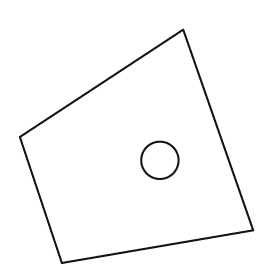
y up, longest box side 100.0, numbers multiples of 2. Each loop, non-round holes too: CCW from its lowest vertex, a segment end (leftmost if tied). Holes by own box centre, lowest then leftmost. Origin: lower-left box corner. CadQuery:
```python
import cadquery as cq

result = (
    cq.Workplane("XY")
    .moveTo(18.0, 0.0)
    .lineTo(100.0, 14.0)
    .lineTo(70.0, 100.0)
    .lineTo(0.0, 54.0)
    .close()
    .moveTo(60.0, 44.0)
    .circle(8.0)
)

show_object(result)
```